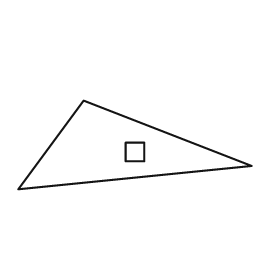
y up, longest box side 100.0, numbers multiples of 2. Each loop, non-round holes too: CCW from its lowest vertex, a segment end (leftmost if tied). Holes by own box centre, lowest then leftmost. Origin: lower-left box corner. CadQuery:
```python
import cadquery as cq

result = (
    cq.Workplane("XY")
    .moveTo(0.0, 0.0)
    .lineTo(100.0, 10.0)
    .lineTo(28.0, 38.0)
    .close()
    .moveTo(46.0, 12.0)
    .lineTo(54.0, 12.0)
    .lineTo(54.0, 20.0)
    .lineTo(46.0, 20.0)
    .close()
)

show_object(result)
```